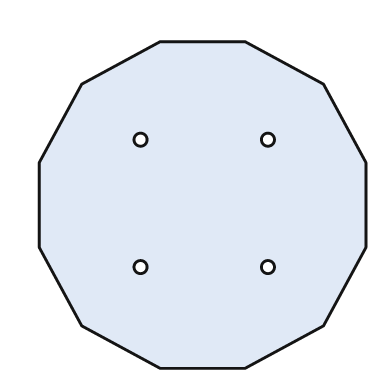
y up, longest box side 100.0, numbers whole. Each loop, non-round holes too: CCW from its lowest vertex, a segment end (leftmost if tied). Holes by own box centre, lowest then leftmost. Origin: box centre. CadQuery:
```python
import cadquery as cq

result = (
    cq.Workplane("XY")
    .moveTo(-13.0, -50.0)
    .lineTo(13.0, -50.0)
    .lineTo(37.0, -37.0)
    .lineTo(50.0, -13.0)
    .lineTo(50.0, 13.0)
    .lineTo(37.0, 37.0)
    .lineTo(13.0, 50.0)
    .lineTo(-13.0, 50.0)
    .lineTo(-37.0, 37.0)
    .lineTo(-50.0, 13.0)
    .lineTo(-50.0, -13.0)
    .lineTo(-37.0, -37.0)
    .close()
    .moveTo(-19.0, -19.0)
    .circle(2.0)
    .moveTo(20.0, -19.0)
    .circle(2.0)
    .moveTo(-19.0, 20.0)
    .circle(2.0)
    .moveTo(20.0, 20.0)
    .circle(2.0)
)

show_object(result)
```